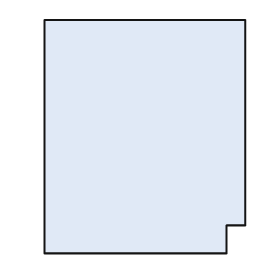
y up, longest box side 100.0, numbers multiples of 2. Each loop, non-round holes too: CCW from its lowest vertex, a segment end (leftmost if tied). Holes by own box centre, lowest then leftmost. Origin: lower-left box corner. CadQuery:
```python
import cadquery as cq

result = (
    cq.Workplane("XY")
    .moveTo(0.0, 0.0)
    .lineTo(78.0, 0.0)
    .lineTo(78.0, 12.0)
    .lineTo(86.0, 12.0)
    .lineTo(86.0, 100.0)
    .lineTo(0.0, 100.0)
    .close()
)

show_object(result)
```